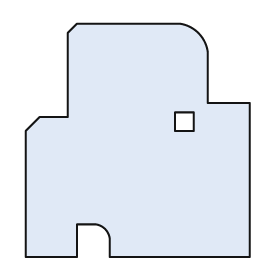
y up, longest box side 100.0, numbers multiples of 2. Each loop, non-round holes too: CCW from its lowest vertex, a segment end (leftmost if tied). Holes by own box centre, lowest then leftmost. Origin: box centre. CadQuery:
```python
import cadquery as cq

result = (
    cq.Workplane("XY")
    .moveTo(-48.0, -50.0)
    .lineTo(-26.0, -50.0)
    .lineTo(-26.0, -36.0)
    .lineTo(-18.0, -36.0)
    .threePointArc((-14.0, -38.0), (-12.0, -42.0))
    .lineTo(-12.0, -50.0)
    .lineTo(48.0, -50.0)
    .lineTo(48.0, 16.0)
    .lineTo(30.0, 16.0)
    .lineTo(30.0, 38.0)
    .threePointArc((26.0, 46.0), (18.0, 50.0))
    .lineTo(-26.0, 50.0)
    .lineTo(-30.0, 46.0)
    .lineTo(-30.0, 10.0)
    .lineTo(-42.0, 10.0)
    .lineTo(-48.0, 4.0)
    .close()
    .moveTo(16.0, 4.0)
    .lineTo(24.0, 4.0)
    .lineTo(24.0, 12.0)
    .lineTo(16.0, 12.0)
    .close()
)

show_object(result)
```